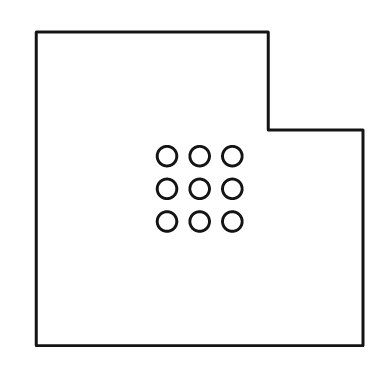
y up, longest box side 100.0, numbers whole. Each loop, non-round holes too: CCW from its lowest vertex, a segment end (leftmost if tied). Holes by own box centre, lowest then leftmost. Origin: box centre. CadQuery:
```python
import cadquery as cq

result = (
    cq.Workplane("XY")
    .moveTo(-50.0, -48.0)
    .lineTo(50.0, -48.0)
    .lineTo(50.0, 18.0)
    .lineTo(21.0, 18.0)
    .lineTo(21.0, 48.0)
    .lineTo(-50.0, 48.0)
    .close()
    .moveTo(-10.0, -10.0)
    .circle(3.0)
    .moveTo(0.0, -10.0)
    .circle(3.0)
    .moveTo(10.0, -10.0)
    .circle(3.0)
    .moveTo(-10.0, 0.0)
    .circle(3.0)
    .moveTo(0.0, 0.0)
    .circle(3.0)
    .moveTo(10.0, 0.0)
    .circle(3.0)
    .moveTo(-10.0, 10.0)
    .circle(3.0)
    .moveTo(0.0, 10.0)
    .circle(3.0)
    .moveTo(10.0, 10.0)
    .circle(3.0)
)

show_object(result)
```